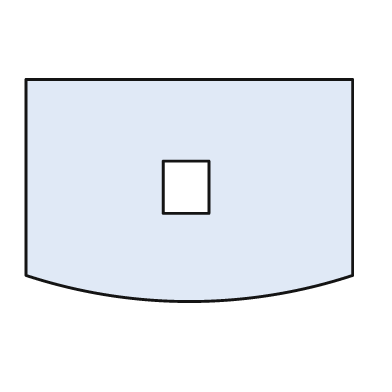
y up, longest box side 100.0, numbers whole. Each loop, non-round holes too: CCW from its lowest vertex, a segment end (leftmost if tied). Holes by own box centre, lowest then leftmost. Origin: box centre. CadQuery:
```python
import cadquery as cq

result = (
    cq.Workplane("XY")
    .moveTo(-50.0, -26.0)
    .threePointArc((0.0, -34.0), (50.0, -26.0))
    .lineTo(50.0, 34.0)
    .lineTo(-50.0, 34.0)
    .close()
    .moveTo(-8.0, -7.0)
    .lineTo(6.0, -7.0)
    .lineTo(6.0, 9.0)
    .lineTo(-8.0, 9.0)
    .close()
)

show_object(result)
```